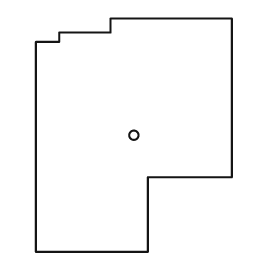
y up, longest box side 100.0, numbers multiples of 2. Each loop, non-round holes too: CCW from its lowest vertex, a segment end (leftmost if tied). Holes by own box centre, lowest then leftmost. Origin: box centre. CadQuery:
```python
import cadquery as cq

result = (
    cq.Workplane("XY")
    .moveTo(-42.0, -50.0)
    .lineTo(6.0, -50.0)
    .lineTo(6.0, -18.0)
    .lineTo(42.0, -18.0)
    .lineTo(42.0, 50.0)
    .lineTo(-10.0, 50.0)
    .lineTo(-10.0, 44.0)
    .lineTo(-32.0, 44.0)
    .lineTo(-32.0, 40.0)
    .lineTo(-42.0, 40.0)
    .close()
    .moveTo(0.0, 0.0)
    .circle(2.0)
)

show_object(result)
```